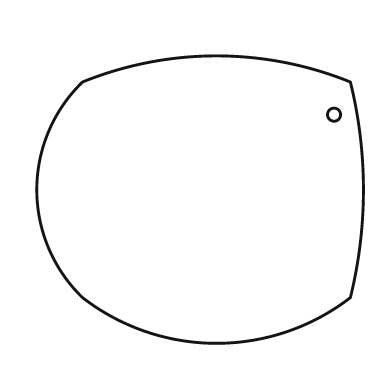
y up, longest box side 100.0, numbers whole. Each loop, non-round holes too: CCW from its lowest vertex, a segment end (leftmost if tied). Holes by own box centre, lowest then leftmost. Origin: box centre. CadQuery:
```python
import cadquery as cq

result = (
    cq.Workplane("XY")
    .moveTo(-36.0, -30.0)
    .threePointArc((5.0, -44.0), (46.0, -30.0))
    .threePointArc((50.0, 3.0), (46.0, 36.0))
    .threePointArc((5.0, 44.0), (-36.0, 36.0))
    .threePointArc((-50.0, 3.0), (-36.0, -30.0))
    .close()
    .moveTo(41.0, 26.0)
    .circle(2.0)
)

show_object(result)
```